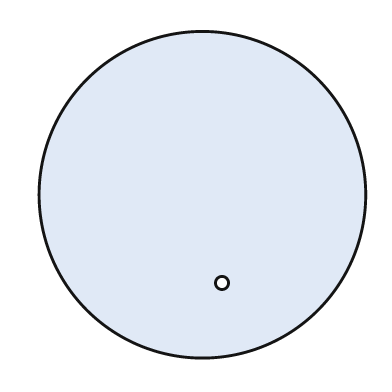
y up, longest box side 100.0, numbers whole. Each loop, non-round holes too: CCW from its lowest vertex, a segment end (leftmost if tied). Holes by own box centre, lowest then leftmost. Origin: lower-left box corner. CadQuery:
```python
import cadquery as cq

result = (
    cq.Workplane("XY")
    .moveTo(50.0, 50.0)
    .circle(50.0)
    .moveTo(56.0, 23.0)
    .circle(2.0)
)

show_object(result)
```